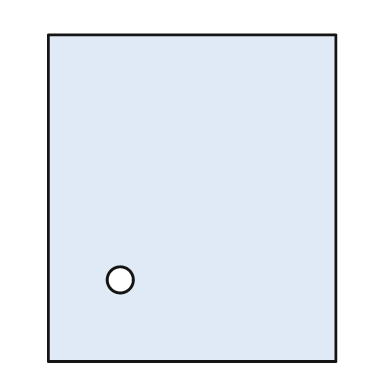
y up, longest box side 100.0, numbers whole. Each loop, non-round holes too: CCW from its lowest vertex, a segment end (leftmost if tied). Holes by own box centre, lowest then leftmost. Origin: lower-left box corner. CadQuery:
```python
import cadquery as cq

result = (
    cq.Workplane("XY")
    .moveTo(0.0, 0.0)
    .lineTo(88.0, 0.0)
    .lineTo(88.0, 100.0)
    .lineTo(0.0, 100.0)
    .close()
    .moveTo(22.0, 25.0)
    .circle(4.0)
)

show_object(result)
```